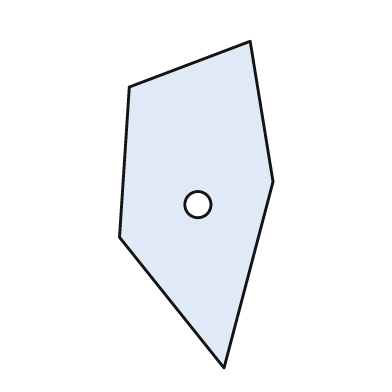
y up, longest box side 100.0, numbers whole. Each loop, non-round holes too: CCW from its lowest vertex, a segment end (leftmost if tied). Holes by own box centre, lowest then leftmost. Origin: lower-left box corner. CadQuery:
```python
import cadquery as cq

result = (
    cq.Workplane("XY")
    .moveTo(32.0, 0.0)
    .lineTo(47.0, 57.0)
    .lineTo(40.0, 100.0)
    .lineTo(3.0, 86.0)
    .lineTo(0.0, 40.0)
    .close()
    .moveTo(24.0, 50.0)
    .circle(4.0)
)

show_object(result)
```